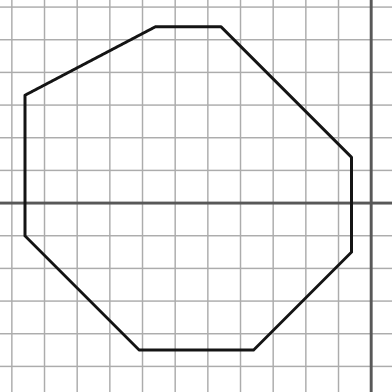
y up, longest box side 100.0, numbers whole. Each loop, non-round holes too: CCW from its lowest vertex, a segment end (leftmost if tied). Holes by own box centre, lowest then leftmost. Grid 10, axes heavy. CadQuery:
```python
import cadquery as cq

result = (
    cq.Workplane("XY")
    .moveTo(-71.0, -45.0)
    .lineTo(-36.0, -45.0)
    .lineTo(-6.0, -15.0)
    .lineTo(-6.0, 14.0)
    .lineTo(-46.0, 54.0)
    .lineTo(-66.0, 54.0)
    .lineTo(-106.0, 33.0)
    .lineTo(-106.0, -10.0)
    .close()
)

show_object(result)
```